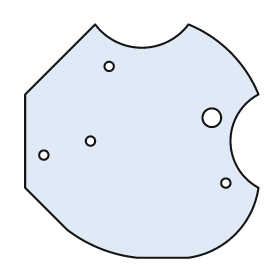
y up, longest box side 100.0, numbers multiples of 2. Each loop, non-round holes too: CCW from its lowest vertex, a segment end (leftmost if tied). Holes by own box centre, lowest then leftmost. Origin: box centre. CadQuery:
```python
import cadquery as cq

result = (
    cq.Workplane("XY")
    .moveTo(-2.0, -50.0)
    .lineTo(20.0, -50.0)
    .threePointArc((40.0, -40.0), (50.0, -20.0))
    .threePointArc((38.0, 0.0), (50.0, 20.0))
    .threePointArc((38.0, 38.0), (20.0, 50.0))
    .threePointArc((0.0, 40.0), (-20.0, 50.0))
    .lineTo(-50.0, 20.0)
    .lineTo(-50.0, -20.0)
    .lineTo(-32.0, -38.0)
    .threePointArc((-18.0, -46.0), (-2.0, -50.0))
    .close()
    .moveTo(36.0, -18.0)
    .circle(2.0)
    .moveTo(-42.0, -6.0)
    .circle(2.0)
    .moveTo(-22.0, 0.0)
    .circle(2.0)
    .moveTo(30.0, 10.0)
    .circle(4.0)
    .moveTo(-14.0, 32.0)
    .circle(2.0)
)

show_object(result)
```